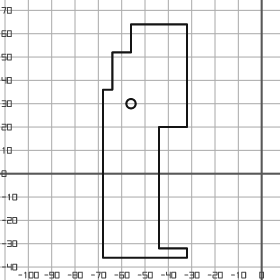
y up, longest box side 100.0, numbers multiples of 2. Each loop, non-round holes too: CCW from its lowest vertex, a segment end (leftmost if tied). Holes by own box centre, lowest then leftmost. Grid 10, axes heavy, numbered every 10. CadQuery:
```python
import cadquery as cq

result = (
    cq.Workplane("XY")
    .moveTo(-68.0, -36.0)
    .lineTo(-32.0, -36.0)
    .lineTo(-32.0, -32.0)
    .lineTo(-44.0, -32.0)
    .lineTo(-44.0, 20.0)
    .lineTo(-32.0, 20.0)
    .lineTo(-32.0, 64.0)
    .lineTo(-56.0, 64.0)
    .lineTo(-56.0, 52.0)
    .lineTo(-64.0, 52.0)
    .lineTo(-64.0, 36.0)
    .lineTo(-68.0, 36.0)
    .close()
    .moveTo(-56.0, 30.0)
    .circle(2.0)
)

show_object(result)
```